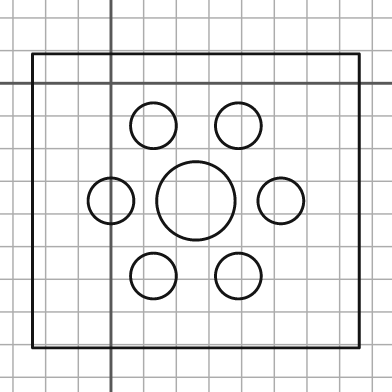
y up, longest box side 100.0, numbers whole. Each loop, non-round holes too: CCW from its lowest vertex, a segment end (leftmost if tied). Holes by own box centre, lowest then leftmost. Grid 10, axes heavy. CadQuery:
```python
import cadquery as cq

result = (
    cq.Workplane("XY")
    .moveTo(-24.0, -81.0)
    .lineTo(76.0, -81.0)
    .lineTo(76.0, 9.0)
    .lineTo(-24.0, 9.0)
    .close()
    .moveTo(13.0, -59.0)
    .circle(7.0)
    .moveTo(39.0, -59.0)
    .circle(7.0)
    .moveTo(0.0, -36.0)
    .circle(7.0)
    .moveTo(26.0, -36.0)
    .circle(12.0)
    .moveTo(52.0, -36.0)
    .circle(7.0)
    .moveTo(13.0, -13.0)
    .circle(7.0)
    .moveTo(39.0, -13.0)
    .circle(7.0)
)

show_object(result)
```